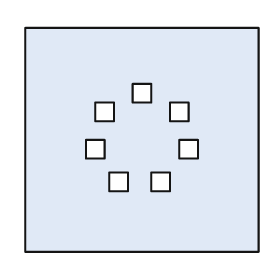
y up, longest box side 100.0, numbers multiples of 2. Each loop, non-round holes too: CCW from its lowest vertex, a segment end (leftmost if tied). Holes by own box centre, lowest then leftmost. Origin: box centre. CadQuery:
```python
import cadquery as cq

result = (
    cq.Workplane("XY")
    .moveTo(-50.0, -48.0)
    .lineTo(50.0, -48.0)
    .lineTo(50.0, 48.0)
    .lineTo(-50.0, 48.0)
    .close()
    .moveTo(-14.0, -22.0)
    .lineTo(-6.0, -22.0)
    .lineTo(-6.0, -14.0)
    .lineTo(-14.0, -14.0)
    .close()
    .moveTo(4.0, -22.0)
    .lineTo(12.0, -22.0)
    .lineTo(12.0, -14.0)
    .lineTo(4.0, -14.0)
    .close()
    .moveTo(-24.0, -8.0)
    .lineTo(-16.0, -8.0)
    .lineTo(-16.0, 0.0)
    .lineTo(-24.0, 0.0)
    .close()
    .moveTo(16.0, -8.0)
    .lineTo(24.0, -8.0)
    .lineTo(24.0, 0.0)
    .lineTo(16.0, 0.0)
    .close()
    .moveTo(-20.0, 8.0)
    .lineTo(-12.0, 8.0)
    .lineTo(-12.0, 16.0)
    .lineTo(-20.0, 16.0)
    .close()
    .moveTo(12.0, 8.0)
    .lineTo(20.0, 8.0)
    .lineTo(20.0, 16.0)
    .lineTo(12.0, 16.0)
    .close()
    .moveTo(-4.0, 16.0)
    .lineTo(4.0, 16.0)
    .lineTo(4.0, 24.0)
    .lineTo(-4.0, 24.0)
    .close()
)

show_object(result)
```